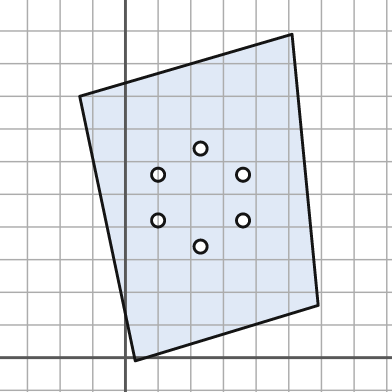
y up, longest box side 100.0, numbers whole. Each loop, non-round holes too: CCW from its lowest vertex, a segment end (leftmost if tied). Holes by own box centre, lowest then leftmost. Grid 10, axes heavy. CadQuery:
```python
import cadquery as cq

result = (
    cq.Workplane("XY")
    .moveTo(3.0, -1.0)
    .lineTo(59.0, 16.0)
    .lineTo(51.0, 99.0)
    .lineTo(-14.0, 80.0)
    .close()
    .moveTo(23.0, 34.0)
    .circle(2.0)
    .moveTo(10.0, 42.0)
    .circle(2.0)
    .moveTo(36.0, 42.0)
    .circle(2.0)
    .moveTo(10.0, 56.0)
    .circle(2.0)
    .moveTo(36.0, 56.0)
    .circle(2.0)
    .moveTo(23.0, 64.0)
    .circle(2.0)
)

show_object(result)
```